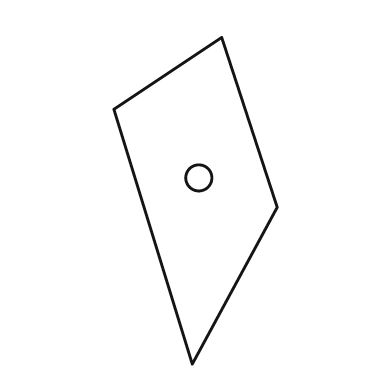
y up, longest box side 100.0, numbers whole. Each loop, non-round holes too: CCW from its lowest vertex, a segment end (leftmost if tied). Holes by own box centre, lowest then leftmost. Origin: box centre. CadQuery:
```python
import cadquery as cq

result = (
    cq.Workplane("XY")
    .moveTo(-1.0, -50.0)
    .lineTo(25.0, -2.0)
    .lineTo(8.0, 50.0)
    .lineTo(-25.0, 28.0)
    .close()
    .moveTo(1.0, 7.0)
    .circle(4.0)
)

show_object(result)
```